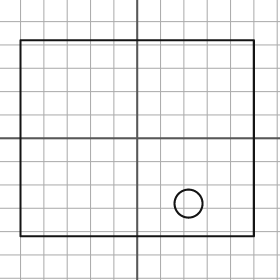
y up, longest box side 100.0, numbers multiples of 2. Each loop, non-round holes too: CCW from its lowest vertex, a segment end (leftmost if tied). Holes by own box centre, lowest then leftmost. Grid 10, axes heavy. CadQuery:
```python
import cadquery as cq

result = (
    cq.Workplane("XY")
    .moveTo(-50.0, -42.0)
    .lineTo(50.0, -42.0)
    .lineTo(50.0, 42.0)
    .lineTo(-50.0, 42.0)
    .close()
    .moveTo(22.0, -28.0)
    .circle(6.0)
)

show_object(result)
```